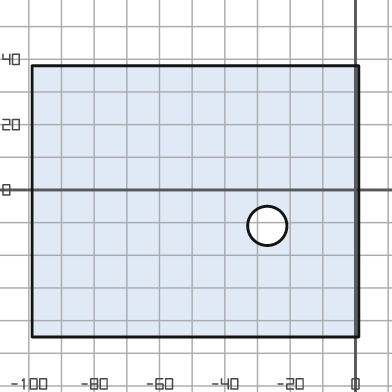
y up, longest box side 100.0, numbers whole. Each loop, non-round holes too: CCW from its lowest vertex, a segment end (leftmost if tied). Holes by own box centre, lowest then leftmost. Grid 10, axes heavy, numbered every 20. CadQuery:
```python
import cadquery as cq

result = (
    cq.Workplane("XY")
    .moveTo(-99.0, -45.0)
    .lineTo(1.0, -45.0)
    .lineTo(1.0, 38.0)
    .lineTo(-99.0, 38.0)
    .close()
    .moveTo(-27.0, -11.0)
    .circle(6.0)
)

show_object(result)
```